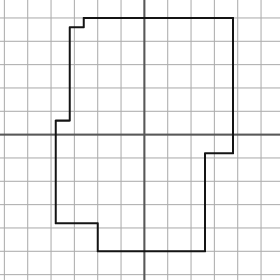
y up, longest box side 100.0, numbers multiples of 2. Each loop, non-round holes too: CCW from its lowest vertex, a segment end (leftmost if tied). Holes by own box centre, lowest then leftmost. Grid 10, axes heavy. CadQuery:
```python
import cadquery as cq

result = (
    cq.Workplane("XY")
    .moveTo(-20.0, -50.0)
    .lineTo(26.0, -50.0)
    .lineTo(26.0, -8.0)
    .lineTo(38.0, -8.0)
    .lineTo(38.0, 50.0)
    .lineTo(-26.0, 50.0)
    .lineTo(-26.0, 46.0)
    .lineTo(-32.0, 46.0)
    .lineTo(-32.0, 6.0)
    .lineTo(-38.0, 6.0)
    .lineTo(-38.0, -38.0)
    .lineTo(-20.0, -38.0)
    .close()
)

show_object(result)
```